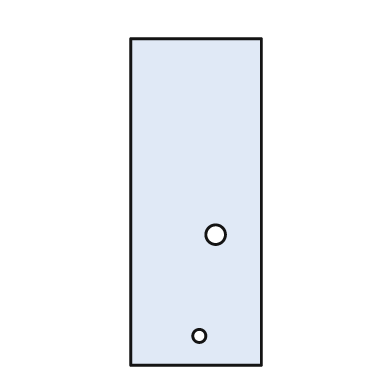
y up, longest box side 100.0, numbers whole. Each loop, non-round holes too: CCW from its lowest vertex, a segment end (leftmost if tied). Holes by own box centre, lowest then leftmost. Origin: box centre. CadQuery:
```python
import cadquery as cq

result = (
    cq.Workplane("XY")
    .moveTo(-20.0, -50.0)
    .lineTo(20.0, -50.0)
    .lineTo(20.0, 50.0)
    .lineTo(-20.0, 50.0)
    .close()
    .moveTo(1.0, -41.0)
    .circle(2.0)
    .moveTo(6.0, -10.0)
    .circle(3.0)
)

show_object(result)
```